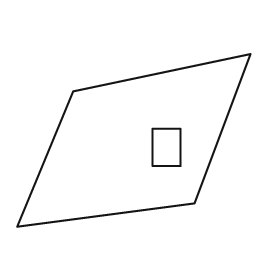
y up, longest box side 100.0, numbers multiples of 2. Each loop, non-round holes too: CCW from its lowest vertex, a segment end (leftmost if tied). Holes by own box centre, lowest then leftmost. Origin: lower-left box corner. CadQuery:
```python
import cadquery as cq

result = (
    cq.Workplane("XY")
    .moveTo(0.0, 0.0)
    .lineTo(76.0, 10.0)
    .lineTo(100.0, 74.0)
    .lineTo(24.0, 58.0)
    .close()
    .moveTo(58.0, 26.0)
    .lineTo(70.0, 26.0)
    .lineTo(70.0, 42.0)
    .lineTo(58.0, 42.0)
    .close()
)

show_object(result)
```